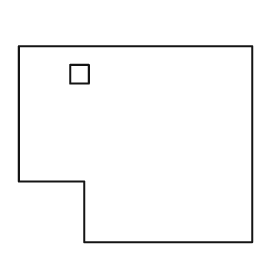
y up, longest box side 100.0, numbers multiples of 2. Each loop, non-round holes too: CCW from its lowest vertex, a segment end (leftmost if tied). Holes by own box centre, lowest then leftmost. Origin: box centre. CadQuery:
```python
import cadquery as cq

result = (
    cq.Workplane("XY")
    .moveTo(-22.0, -42.0)
    .lineTo(50.0, -42.0)
    .lineTo(50.0, 42.0)
    .lineTo(-50.0, 42.0)
    .lineTo(-50.0, -16.0)
    .lineTo(-22.0, -16.0)
    .close()
    .moveTo(-28.0, 26.0)
    .lineTo(-20.0, 26.0)
    .lineTo(-20.0, 34.0)
    .lineTo(-28.0, 34.0)
    .close()
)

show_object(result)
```